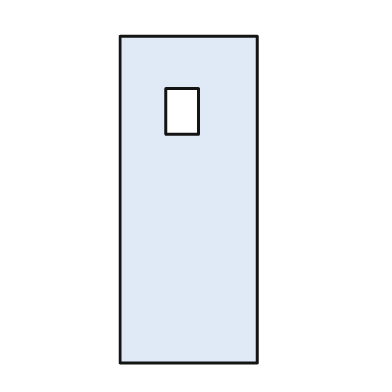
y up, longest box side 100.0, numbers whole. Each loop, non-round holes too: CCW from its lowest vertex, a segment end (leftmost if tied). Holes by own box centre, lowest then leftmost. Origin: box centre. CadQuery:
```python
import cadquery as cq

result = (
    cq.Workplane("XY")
    .moveTo(-21.0, -50.0)
    .lineTo(21.0, -50.0)
    .lineTo(21.0, 50.0)
    .lineTo(-21.0, 50.0)
    .close()
    .moveTo(-7.0, 20.0)
    .lineTo(3.0, 20.0)
    .lineTo(3.0, 34.0)
    .lineTo(-7.0, 34.0)
    .close()
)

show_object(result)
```